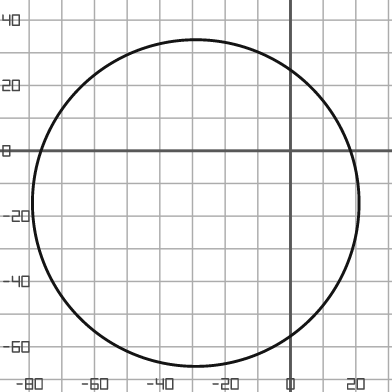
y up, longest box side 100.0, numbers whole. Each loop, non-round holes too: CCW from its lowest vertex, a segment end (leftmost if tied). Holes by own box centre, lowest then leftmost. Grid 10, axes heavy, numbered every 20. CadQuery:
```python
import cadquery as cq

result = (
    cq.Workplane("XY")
    .moveTo(-29.0, -16.0)
    .circle(50.0)
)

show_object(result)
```